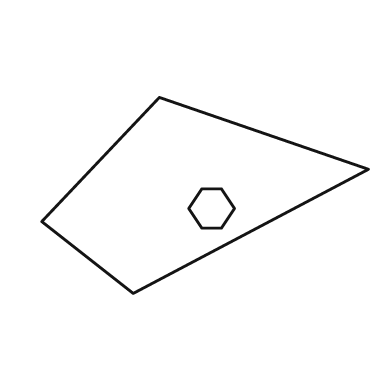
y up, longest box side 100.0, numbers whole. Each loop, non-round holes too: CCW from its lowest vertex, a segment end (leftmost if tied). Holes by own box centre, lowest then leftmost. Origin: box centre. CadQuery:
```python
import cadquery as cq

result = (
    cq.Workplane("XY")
    .moveTo(-22.0, -30.0)
    .lineTo(50.0, 8.0)
    .lineTo(-14.0, 30.0)
    .lineTo(-50.0, -8.0)
    .close()
    .moveTo(-1.0, -10.0)
    .lineTo(5.0, -10.0)
    .lineTo(9.0, -4.0)
    .lineTo(5.0, 2.0)
    .lineTo(-1.0, 2.0)
    .lineTo(-5.0, -4.0)
    .close()
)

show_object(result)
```